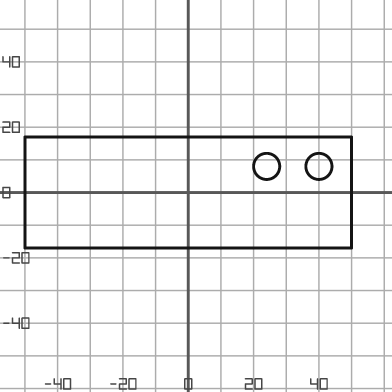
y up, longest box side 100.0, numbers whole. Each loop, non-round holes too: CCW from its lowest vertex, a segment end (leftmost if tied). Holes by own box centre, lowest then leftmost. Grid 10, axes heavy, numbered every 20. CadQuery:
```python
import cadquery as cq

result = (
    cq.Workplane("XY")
    .moveTo(-50.0, -17.0)
    .lineTo(50.0, -17.0)
    .lineTo(50.0, 17.0)
    .lineTo(-50.0, 17.0)
    .close()
    .moveTo(24.0, 8.0)
    .circle(4.0)
    .moveTo(40.0, 8.0)
    .circle(4.0)
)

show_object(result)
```